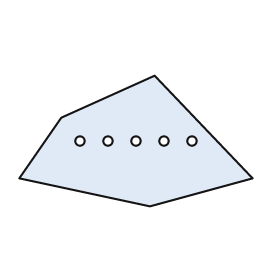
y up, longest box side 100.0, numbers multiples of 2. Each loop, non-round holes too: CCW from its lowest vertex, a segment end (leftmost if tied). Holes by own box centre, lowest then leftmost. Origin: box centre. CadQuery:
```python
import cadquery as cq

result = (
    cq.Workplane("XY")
    .moveTo(6.0, -28.0)
    .lineTo(50.0, -16.0)
    .lineTo(8.0, 28.0)
    .lineTo(-32.0, 10.0)
    .lineTo(-50.0, -16.0)
    .close()
    .moveTo(-24.0, 0.0)
    .circle(2.0)
    .moveTo(-12.0, 0.0)
    .circle(2.0)
    .moveTo(0.0, 0.0)
    .circle(2.0)
    .moveTo(12.0, 0.0)
    .circle(2.0)
    .moveTo(24.0, 0.0)
    .circle(2.0)
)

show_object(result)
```